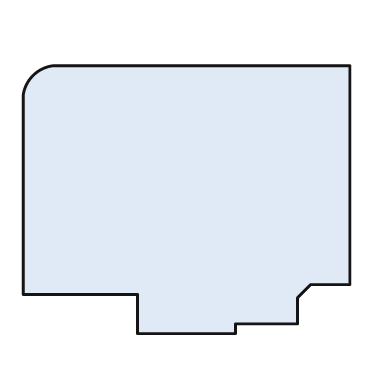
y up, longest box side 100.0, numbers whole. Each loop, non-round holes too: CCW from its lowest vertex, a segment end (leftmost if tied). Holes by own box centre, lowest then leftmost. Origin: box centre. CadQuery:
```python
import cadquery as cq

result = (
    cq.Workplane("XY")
    .moveTo(-15.0, -41.0)
    .lineTo(15.0, -41.0)
    .lineTo(15.0, -38.0)
    .lineTo(34.0, -38.0)
    .lineTo(34.0, -30.0)
    .lineTo(38.0, -26.0)
    .lineTo(50.0, -26.0)
    .lineTo(50.0, 41.0)
    .lineTo(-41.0, 41.0)
    .threePointArc((-47.0, 38.0), (-50.0, 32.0))
    .lineTo(-50.0, -29.0)
    .lineTo(-15.0, -29.0)
    .close()
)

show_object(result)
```